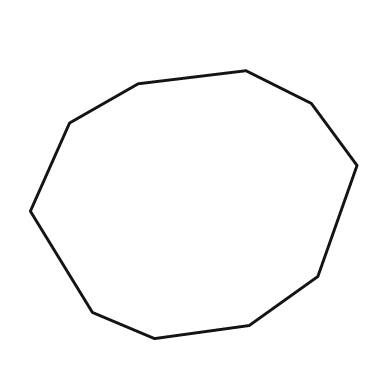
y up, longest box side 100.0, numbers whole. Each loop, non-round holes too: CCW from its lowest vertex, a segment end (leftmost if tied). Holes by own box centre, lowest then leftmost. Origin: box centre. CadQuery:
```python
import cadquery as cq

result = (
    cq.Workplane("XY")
    .moveTo(-12.0, -41.0)
    .lineTo(17.0, -37.0)
    .lineTo(38.0, -22.0)
    .lineTo(50.0, 12.0)
    .lineTo(36.0, 31.0)
    .lineTo(16.0, 41.0)
    .lineTo(-17.0, 37.0)
    .lineTo(-38.0, 25.0)
    .lineTo(-50.0, -2.0)
    .lineTo(-31.0, -33.0)
    .close()
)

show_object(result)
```